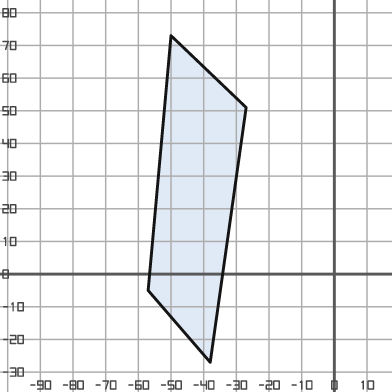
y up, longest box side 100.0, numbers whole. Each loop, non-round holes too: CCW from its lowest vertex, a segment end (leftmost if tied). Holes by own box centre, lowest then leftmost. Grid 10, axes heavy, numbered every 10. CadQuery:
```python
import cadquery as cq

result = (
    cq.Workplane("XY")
    .moveTo(-38.0, -27.0)
    .lineTo(-27.0, 51.0)
    .lineTo(-50.0, 73.0)
    .lineTo(-57.0, -5.0)
    .close()
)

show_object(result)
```